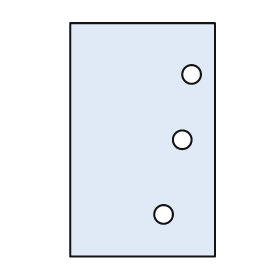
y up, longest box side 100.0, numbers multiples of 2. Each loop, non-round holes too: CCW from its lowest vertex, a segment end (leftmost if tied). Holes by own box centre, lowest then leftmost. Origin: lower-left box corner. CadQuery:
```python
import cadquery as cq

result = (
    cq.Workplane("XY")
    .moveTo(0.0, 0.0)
    .lineTo(62.0, 0.0)
    .lineTo(62.0, 100.0)
    .lineTo(0.0, 100.0)
    .close()
    .moveTo(40.0, 18.0)
    .circle(4.0)
    .moveTo(48.0, 50.0)
    .circle(4.0)
    .moveTo(52.0, 78.0)
    .circle(4.0)
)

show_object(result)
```